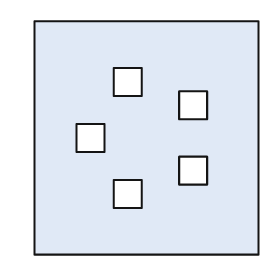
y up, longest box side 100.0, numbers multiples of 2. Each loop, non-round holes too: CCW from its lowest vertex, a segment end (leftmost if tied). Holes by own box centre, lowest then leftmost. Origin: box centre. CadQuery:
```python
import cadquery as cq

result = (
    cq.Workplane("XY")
    .moveTo(-48.0, -50.0)
    .lineTo(48.0, -50.0)
    .lineTo(48.0, 50.0)
    .lineTo(-48.0, 50.0)
    .close()
    .moveTo(-14.0, -30.0)
    .lineTo(-2.0, -30.0)
    .lineTo(-2.0, -18.0)
    .lineTo(-14.0, -18.0)
    .close()
    .moveTo(14.0, -20.0)
    .lineTo(26.0, -20.0)
    .lineTo(26.0, -8.0)
    .lineTo(14.0, -8.0)
    .close()
    .moveTo(-30.0, -6.0)
    .lineTo(-18.0, -6.0)
    .lineTo(-18.0, 6.0)
    .lineTo(-30.0, 6.0)
    .close()
    .moveTo(14.0, 8.0)
    .lineTo(26.0, 8.0)
    .lineTo(26.0, 20.0)
    .lineTo(14.0, 20.0)
    .close()
    .moveTo(-14.0, 18.0)
    .lineTo(-2.0, 18.0)
    .lineTo(-2.0, 30.0)
    .lineTo(-14.0, 30.0)
    .close()
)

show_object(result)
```